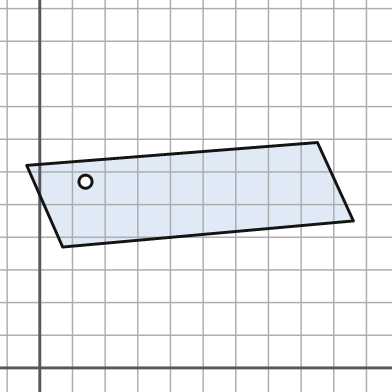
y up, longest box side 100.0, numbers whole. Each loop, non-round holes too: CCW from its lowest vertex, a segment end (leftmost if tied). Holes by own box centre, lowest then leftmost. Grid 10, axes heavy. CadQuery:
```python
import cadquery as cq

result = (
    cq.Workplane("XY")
    .moveTo(7.0, 37.0)
    .lineTo(96.0, 45.0)
    .lineTo(85.0, 69.0)
    .lineTo(-4.0, 62.0)
    .close()
    .moveTo(14.0, 57.0)
    .circle(2.0)
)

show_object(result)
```